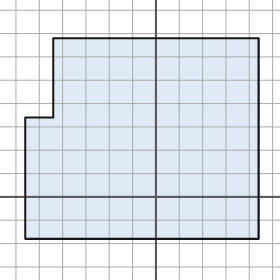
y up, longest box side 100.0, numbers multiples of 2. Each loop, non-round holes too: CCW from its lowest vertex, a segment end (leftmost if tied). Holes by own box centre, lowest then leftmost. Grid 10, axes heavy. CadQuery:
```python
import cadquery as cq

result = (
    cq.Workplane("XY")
    .moveTo(-56.0, -18.0)
    .lineTo(44.0, -18.0)
    .lineTo(44.0, 68.0)
    .lineTo(-44.0, 68.0)
    .lineTo(-44.0, 34.0)
    .lineTo(-56.0, 34.0)
    .close()
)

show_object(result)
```